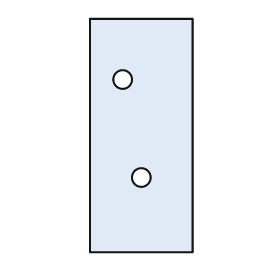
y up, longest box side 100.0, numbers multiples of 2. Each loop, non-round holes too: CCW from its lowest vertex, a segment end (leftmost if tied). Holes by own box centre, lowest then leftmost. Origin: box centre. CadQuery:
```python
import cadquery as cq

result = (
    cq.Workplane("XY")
    .moveTo(-22.0, -50.0)
    .lineTo(22.0, -50.0)
    .lineTo(22.0, 50.0)
    .lineTo(-22.0, 50.0)
    .close()
    .moveTo(0.0, -18.0)
    .circle(4.0)
    .moveTo(-8.0, 24.0)
    .circle(4.0)
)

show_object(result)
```